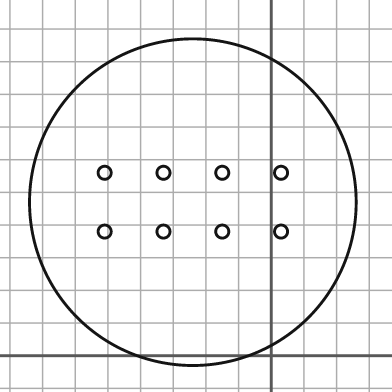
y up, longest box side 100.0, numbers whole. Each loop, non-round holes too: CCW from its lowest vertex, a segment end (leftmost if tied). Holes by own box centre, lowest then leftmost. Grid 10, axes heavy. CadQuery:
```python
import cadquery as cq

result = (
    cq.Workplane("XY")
    .moveTo(-24.0, 47.0)
    .circle(50.0)
    .moveTo(-51.0, 38.0)
    .circle(2.0)
    .moveTo(-33.0, 38.0)
    .circle(2.0)
    .moveTo(-15.0, 38.0)
    .circle(2.0)
    .moveTo(3.0, 38.0)
    .circle(2.0)
    .moveTo(-51.0, 56.0)
    .circle(2.0)
    .moveTo(-33.0, 56.0)
    .circle(2.0)
    .moveTo(-15.0, 56.0)
    .circle(2.0)
    .moveTo(3.0, 56.0)
    .circle(2.0)
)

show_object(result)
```